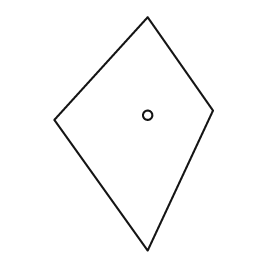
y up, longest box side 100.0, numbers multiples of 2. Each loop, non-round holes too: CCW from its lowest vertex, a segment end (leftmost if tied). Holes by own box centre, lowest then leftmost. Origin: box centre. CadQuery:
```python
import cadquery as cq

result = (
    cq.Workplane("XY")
    .moveTo(6.0, -50.0)
    .lineTo(34.0, 10.0)
    .lineTo(6.0, 50.0)
    .lineTo(-34.0, 6.0)
    .close()
    .moveTo(6.0, 8.0)
    .circle(2.0)
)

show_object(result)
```